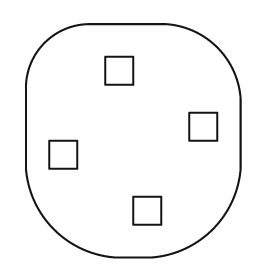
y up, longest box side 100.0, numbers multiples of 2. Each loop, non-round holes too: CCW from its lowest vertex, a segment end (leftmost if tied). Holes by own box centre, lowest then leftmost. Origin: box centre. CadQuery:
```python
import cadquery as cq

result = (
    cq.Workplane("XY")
    .moveTo(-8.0, -50.0)
    .lineTo(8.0, -50.0)
    .threePointArc((34.0, -38.0), (46.0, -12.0))
    .lineTo(46.0, 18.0)
    .threePointArc((36.0, 40.0), (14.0, 50.0))
    .lineTo(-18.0, 50.0)
    .threePointArc((-38.0, 42.0), (-46.0, 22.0))
    .lineTo(-46.0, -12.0)
    .threePointArc((-34.0, -38.0), (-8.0, -50.0))
    .close()
    .moveTo(0.0, -36.0)
    .lineTo(12.0, -36.0)
    .lineTo(12.0, -24.0)
    .lineTo(0.0, -24.0)
    .close()
    .moveTo(-36.0, -12.0)
    .lineTo(-24.0, -12.0)
    .lineTo(-24.0, 0.0)
    .lineTo(-36.0, 0.0)
    .close()
    .moveTo(24.0, 0.0)
    .lineTo(36.0, 0.0)
    .lineTo(36.0, 12.0)
    .lineTo(24.0, 12.0)
    .close()
    .moveTo(-12.0, 24.0)
    .lineTo(0.0, 24.0)
    .lineTo(0.0, 36.0)
    .lineTo(-12.0, 36.0)
    .close()
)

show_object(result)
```